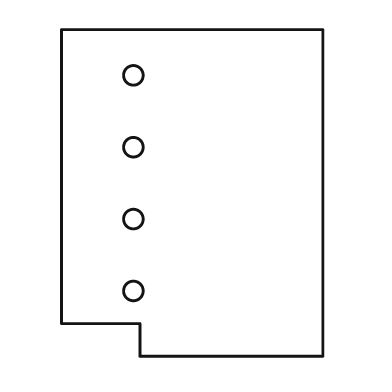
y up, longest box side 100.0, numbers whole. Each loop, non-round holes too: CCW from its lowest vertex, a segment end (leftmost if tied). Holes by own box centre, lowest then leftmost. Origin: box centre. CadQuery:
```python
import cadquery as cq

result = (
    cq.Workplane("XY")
    .moveTo(-16.0, -50.0)
    .lineTo(40.0, -50.0)
    .lineTo(40.0, 50.0)
    .lineTo(-40.0, 50.0)
    .lineTo(-40.0, -40.0)
    .lineTo(-16.0, -40.0)
    .close()
    .moveTo(-18.0, -30.0)
    .circle(3.0)
    .moveTo(-18.0, -8.0)
    .circle(3.0)
    .moveTo(-18.0, 14.0)
    .circle(3.0)
    .moveTo(-18.0, 36.0)
    .circle(3.0)
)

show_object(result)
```